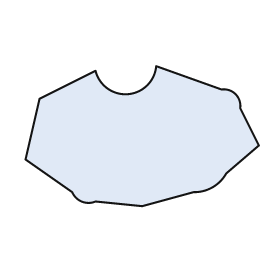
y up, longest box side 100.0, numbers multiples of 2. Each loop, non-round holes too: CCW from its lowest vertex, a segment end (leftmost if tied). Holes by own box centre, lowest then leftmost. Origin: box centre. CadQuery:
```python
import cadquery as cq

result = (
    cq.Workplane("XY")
    .moveTo(0.0, -30.0)
    .lineTo(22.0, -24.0)
    .threePointArc((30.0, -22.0), (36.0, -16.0))
    .lineTo(50.0, -4.0)
    .lineTo(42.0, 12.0)
    .threePointArc((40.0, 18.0), (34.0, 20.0))
    .lineTo(6.0, 30.0)
    .threePointArc((-6.0, 18.0), (-20.0, 28.0))
    .lineTo(-44.0, 16.0)
    .lineTo(-50.0, -10.0)
    .lineTo(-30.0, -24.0)
    .threePointArc((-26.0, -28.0), (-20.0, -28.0))
    .close()
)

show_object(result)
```